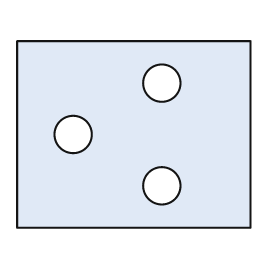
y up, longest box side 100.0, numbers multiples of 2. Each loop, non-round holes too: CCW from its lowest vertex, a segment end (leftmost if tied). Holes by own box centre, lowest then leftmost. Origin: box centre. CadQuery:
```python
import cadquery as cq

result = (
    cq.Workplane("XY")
    .moveTo(-50.0, -40.0)
    .lineTo(50.0, -40.0)
    .lineTo(50.0, 40.0)
    .lineTo(-50.0, 40.0)
    .close()
    .moveTo(12.0, -22.0)
    .circle(8.0)
    .moveTo(-26.0, 0.0)
    .circle(8.0)
    .moveTo(12.0, 22.0)
    .circle(8.0)
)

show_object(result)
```